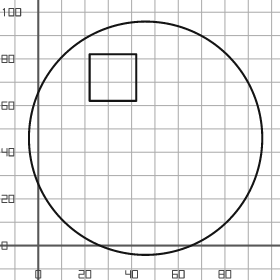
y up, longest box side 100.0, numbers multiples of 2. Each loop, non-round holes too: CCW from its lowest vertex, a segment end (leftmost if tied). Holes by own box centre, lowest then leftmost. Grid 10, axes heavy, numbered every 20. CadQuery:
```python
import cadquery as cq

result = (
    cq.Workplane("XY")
    .moveTo(46.0, 46.0)
    .circle(50.0)
    .moveTo(22.0, 62.0)
    .lineTo(42.0, 62.0)
    .lineTo(42.0, 82.0)
    .lineTo(22.0, 82.0)
    .close()
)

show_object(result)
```